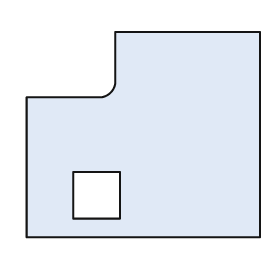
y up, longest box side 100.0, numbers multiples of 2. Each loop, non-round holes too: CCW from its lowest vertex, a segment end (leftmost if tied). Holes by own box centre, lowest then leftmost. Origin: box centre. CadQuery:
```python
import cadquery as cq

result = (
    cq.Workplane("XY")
    .moveTo(-50.0, -44.0)
    .lineTo(50.0, -44.0)
    .lineTo(50.0, 44.0)
    .lineTo(-12.0, 44.0)
    .lineTo(-12.0, 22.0)
    .threePointArc((-14.0, 18.0), (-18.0, 16.0))
    .lineTo(-50.0, 16.0)
    .close()
    .moveTo(-30.0, -36.0)
    .lineTo(-10.0, -36.0)
    .lineTo(-10.0, -16.0)
    .lineTo(-30.0, -16.0)
    .close()
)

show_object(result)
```